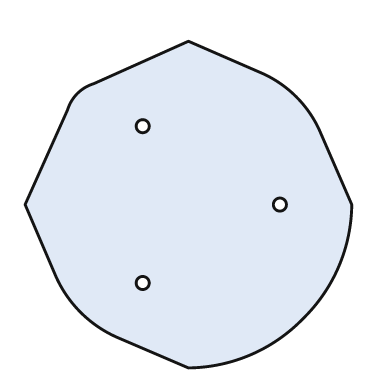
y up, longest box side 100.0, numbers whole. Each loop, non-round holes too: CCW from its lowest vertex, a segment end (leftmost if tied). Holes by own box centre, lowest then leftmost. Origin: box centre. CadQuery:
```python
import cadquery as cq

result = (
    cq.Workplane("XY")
    .moveTo(0.0, -50.0)
    .threePointArc((19.0, -46.0), (35.0, -35.0))
    .threePointArc((46.0, -19.0), (50.0, 0.0))
    .lineTo(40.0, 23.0)
    .threePointArc((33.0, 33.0), (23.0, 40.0))
    .lineTo(0.0, 50.0)
    .lineTo(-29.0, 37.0)
    .threePointArc((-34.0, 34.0), (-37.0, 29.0))
    .lineTo(-50.0, 0.0)
    .lineTo(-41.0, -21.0)
    .threePointArc((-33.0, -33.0), (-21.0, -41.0))
    .close()
    .moveTo(-14.0, -24.0)
    .circle(2.0)
    .moveTo(28.0, 0.0)
    .circle(2.0)
    .moveTo(-14.0, 24.0)
    .circle(2.0)
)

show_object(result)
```